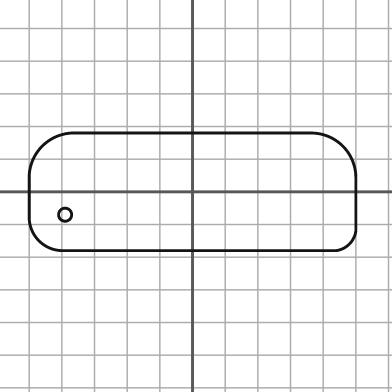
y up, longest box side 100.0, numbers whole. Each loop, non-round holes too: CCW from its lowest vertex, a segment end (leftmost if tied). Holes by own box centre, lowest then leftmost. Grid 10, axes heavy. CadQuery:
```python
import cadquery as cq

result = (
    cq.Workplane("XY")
    .moveTo(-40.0, -18.0)
    .lineTo(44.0, -18.0)
    .threePointArc((48.0, -16.0), (50.0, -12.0))
    .lineTo(50.0, 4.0)
    .threePointArc((46.0, 14.0), (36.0, 18.0))
    .lineTo(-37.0, 18.0)
    .threePointArc((-46.0, 14.0), (-50.0, 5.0))
    .lineTo(-50.0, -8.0)
    .threePointArc((-47.0, -15.0), (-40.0, -18.0))
    .close()
    .moveTo(-39.0, -7.0)
    .circle(2.0)
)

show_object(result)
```